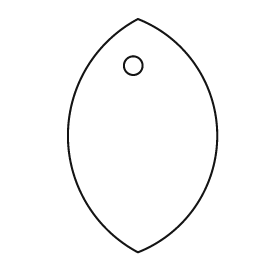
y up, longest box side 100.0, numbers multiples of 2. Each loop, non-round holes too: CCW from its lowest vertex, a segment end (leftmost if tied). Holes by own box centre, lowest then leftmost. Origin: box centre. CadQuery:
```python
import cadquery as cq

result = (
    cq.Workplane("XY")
    .moveTo(-2.0, -50.0)
    .threePointArc((32.0, 0.0), (-2.0, 50.0))
    .threePointArc((-32.0, 0.0), (-2.0, -50.0))
    .close()
    .moveTo(-4.0, 30.0)
    .circle(4.0)
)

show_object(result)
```